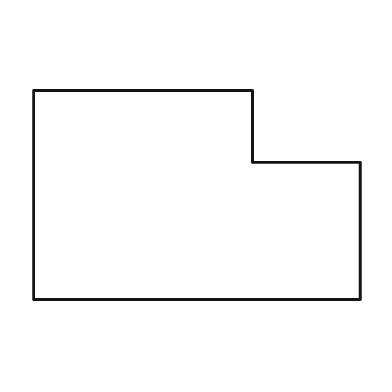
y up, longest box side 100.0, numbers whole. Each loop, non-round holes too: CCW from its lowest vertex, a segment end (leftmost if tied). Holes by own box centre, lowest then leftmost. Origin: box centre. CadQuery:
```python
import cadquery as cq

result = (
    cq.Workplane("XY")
    .moveTo(-50.0, -32.0)
    .lineTo(50.0, -32.0)
    .lineTo(50.0, 10.0)
    .lineTo(17.0, 10.0)
    .lineTo(17.0, 32.0)
    .lineTo(-50.0, 32.0)
    .close()
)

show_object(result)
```